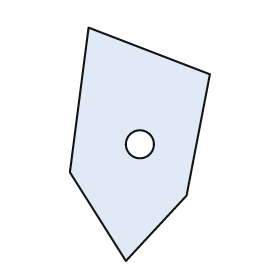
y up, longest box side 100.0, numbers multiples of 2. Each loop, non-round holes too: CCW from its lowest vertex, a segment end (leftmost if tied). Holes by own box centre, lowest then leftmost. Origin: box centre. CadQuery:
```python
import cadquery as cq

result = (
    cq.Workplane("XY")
    .moveTo(-6.0, -50.0)
    .lineTo(20.0, -22.0)
    .lineTo(30.0, 30.0)
    .lineTo(-22.0, 50.0)
    .lineTo(-30.0, -12.0)
    .close()
    .moveTo(0.0, 0.0)
    .circle(6.0)
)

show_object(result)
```